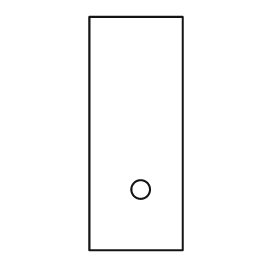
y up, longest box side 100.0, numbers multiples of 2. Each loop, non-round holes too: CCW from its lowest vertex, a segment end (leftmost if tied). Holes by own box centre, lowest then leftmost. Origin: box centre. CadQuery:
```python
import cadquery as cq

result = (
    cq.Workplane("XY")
    .moveTo(-20.0, -50.0)
    .lineTo(20.0, -50.0)
    .lineTo(20.0, 50.0)
    .lineTo(-20.0, 50.0)
    .close()
    .moveTo(2.0, -24.0)
    .circle(4.0)
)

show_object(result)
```